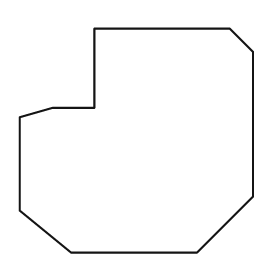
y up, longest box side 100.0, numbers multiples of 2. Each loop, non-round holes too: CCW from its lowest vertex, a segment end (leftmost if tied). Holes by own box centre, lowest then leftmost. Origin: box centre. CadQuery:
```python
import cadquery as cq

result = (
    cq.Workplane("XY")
    .moveTo(-28.0, -48.0)
    .lineTo(26.0, -48.0)
    .lineTo(50.0, -24.0)
    .lineTo(50.0, 38.0)
    .lineTo(40.0, 48.0)
    .lineTo(-18.0, 48.0)
    .lineTo(-18.0, 14.0)
    .lineTo(-36.0, 14.0)
    .lineTo(-50.0, 10.0)
    .lineTo(-50.0, -30.0)
    .close()
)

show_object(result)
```